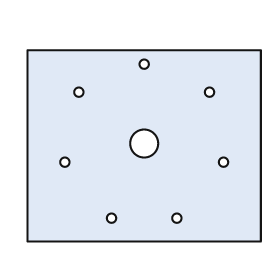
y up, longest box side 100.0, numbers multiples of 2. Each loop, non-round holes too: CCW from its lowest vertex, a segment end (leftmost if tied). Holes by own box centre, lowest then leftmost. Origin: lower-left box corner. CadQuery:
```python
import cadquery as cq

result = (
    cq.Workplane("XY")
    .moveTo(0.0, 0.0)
    .lineTo(100.0, 0.0)
    .lineTo(100.0, 82.0)
    .lineTo(0.0, 82.0)
    .close()
    .moveTo(36.0, 10.0)
    .circle(2.0)
    .moveTo(64.0, 10.0)
    .circle(2.0)
    .moveTo(16.0, 34.0)
    .circle(2.0)
    .moveTo(84.0, 34.0)
    .circle(2.0)
    .moveTo(50.0, 42.0)
    .circle(6.0)
    .moveTo(22.0, 64.0)
    .circle(2.0)
    .moveTo(78.0, 64.0)
    .circle(2.0)
    .moveTo(50.0, 76.0)
    .circle(2.0)
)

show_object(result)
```